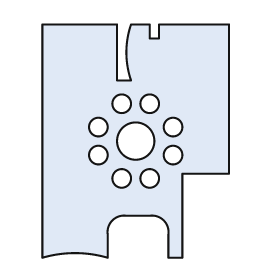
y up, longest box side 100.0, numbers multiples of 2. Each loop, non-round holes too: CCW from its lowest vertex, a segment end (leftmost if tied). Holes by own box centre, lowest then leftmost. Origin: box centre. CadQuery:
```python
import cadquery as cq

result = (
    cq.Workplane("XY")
    .moveTo(-40.0, -50.0)
    .threePointArc((-26.0, -48.0), (-12.0, -50.0))
    .lineTo(-12.0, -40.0)
    .threePointArc((-10.0, -34.0), (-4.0, -32.0))
    .lineTo(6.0, -32.0)
    .threePointArc((12.0, -34.0), (14.0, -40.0))
    .lineTo(14.0, -50.0)
    .lineTo(20.0, -50.0)
    .lineTo(20.0, -14.0)
    .lineTo(40.0, -14.0)
    .lineTo(40.0, 50.0)
    .lineTo(10.0, 50.0)
    .lineTo(10.0, 44.0)
    .lineTo(6.0, 44.0)
    .lineTo(6.0, 50.0)
    .lineTo(-2.0, 50.0)
    .threePointArc((-4.0, 38.0), (-2.0, 26.0))
    .lineTo(-8.0, 26.0)
    .lineTo(-8.0, 50.0)
    .lineTo(-40.0, 50.0)
    .close()
    .moveTo(-6.0, -16.0)
    .circle(4.0)
    .moveTo(6.0, -16.0)
    .circle(4.0)
    .moveTo(-16.0, -6.0)
    .circle(4.0)
    .moveTo(16.0, -6.0)
    .circle(4.0)
    .moveTo(0.0, 0.0)
    .circle(8.0)
    .moveTo(-16.0, 6.0)
    .circle(4.0)
    .moveTo(16.0, 6.0)
    .circle(4.0)
    .moveTo(-6.0, 16.0)
    .circle(4.0)
    .moveTo(6.0, 16.0)
    .circle(4.0)
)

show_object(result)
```